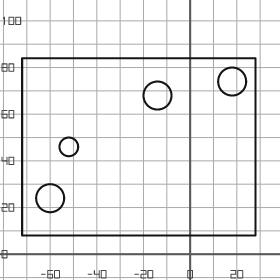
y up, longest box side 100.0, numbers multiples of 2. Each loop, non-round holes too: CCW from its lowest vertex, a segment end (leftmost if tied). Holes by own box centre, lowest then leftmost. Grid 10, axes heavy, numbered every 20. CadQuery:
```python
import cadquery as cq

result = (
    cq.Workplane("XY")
    .moveTo(-72.0, 8.0)
    .lineTo(28.0, 8.0)
    .lineTo(28.0, 84.0)
    .lineTo(-72.0, 84.0)
    .close()
    .moveTo(-60.0, 24.0)
    .circle(6.0)
    .moveTo(-52.0, 46.0)
    .circle(4.0)
    .moveTo(-14.0, 68.0)
    .circle(6.0)
    .moveTo(18.0, 74.0)
    .circle(6.0)
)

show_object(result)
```